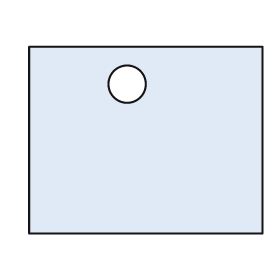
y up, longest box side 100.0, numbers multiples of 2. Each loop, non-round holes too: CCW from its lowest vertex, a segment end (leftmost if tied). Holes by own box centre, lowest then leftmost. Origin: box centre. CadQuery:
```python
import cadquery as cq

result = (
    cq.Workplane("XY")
    .moveTo(-50.0, -40.0)
    .lineTo(50.0, -40.0)
    .lineTo(50.0, 40.0)
    .lineTo(-50.0, 40.0)
    .close()
    .moveTo(-8.0, 24.0)
    .circle(8.0)
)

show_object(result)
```